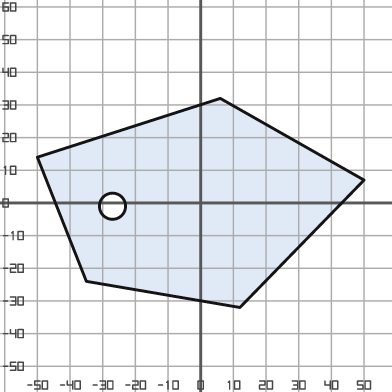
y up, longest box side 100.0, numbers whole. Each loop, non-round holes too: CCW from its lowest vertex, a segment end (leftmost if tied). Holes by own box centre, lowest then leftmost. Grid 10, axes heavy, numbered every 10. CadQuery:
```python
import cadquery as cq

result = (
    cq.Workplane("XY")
    .moveTo(12.0, -32.0)
    .lineTo(50.0, 7.0)
    .lineTo(6.0, 32.0)
    .lineTo(-50.0, 14.0)
    .lineTo(-35.0, -24.0)
    .close()
    .moveTo(-27.0, -1.0)
    .circle(4.0)
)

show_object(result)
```